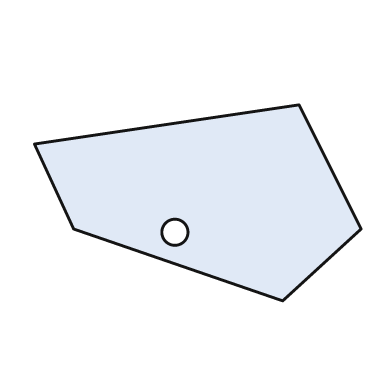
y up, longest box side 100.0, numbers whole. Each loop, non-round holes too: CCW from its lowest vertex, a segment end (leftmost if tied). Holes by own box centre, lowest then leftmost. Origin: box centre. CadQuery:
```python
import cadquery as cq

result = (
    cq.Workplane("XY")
    .moveTo(26.0, -30.0)
    .lineTo(50.0, -8.0)
    .lineTo(31.0, 30.0)
    .lineTo(-50.0, 18.0)
    .lineTo(-38.0, -8.0)
    .close()
    .moveTo(-7.0, -9.0)
    .circle(4.0)
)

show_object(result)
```